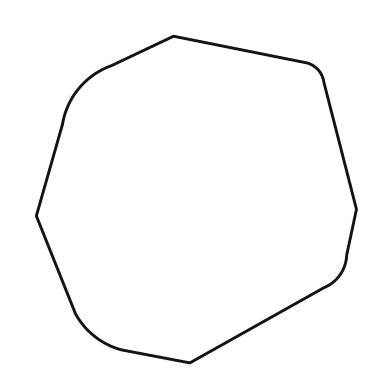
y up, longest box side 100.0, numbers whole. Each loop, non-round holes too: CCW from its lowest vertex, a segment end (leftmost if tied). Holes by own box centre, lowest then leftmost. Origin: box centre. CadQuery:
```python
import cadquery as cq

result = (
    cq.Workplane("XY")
    .moveTo(-2.0, -50.0)
    .lineTo(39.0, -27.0)
    .threePointArc((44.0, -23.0), (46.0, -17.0))
    .lineTo(49.0, -3.0)
    .lineTo(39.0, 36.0)
    .threePointArc((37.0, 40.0), (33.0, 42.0))
    .lineTo(-7.0, 50.0)
    .lineTo(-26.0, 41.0)
    .threePointArc((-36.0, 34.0), (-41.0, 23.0))
    .lineTo(-49.0, -5.0)
    .lineTo(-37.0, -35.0)
    .threePointArc((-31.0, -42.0), (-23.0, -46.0))
    .close()
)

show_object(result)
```